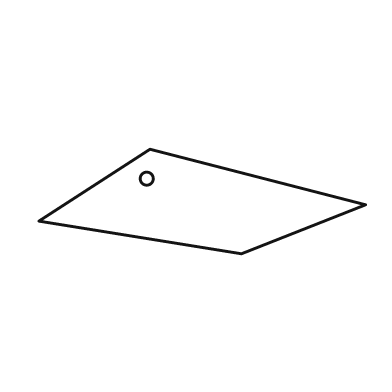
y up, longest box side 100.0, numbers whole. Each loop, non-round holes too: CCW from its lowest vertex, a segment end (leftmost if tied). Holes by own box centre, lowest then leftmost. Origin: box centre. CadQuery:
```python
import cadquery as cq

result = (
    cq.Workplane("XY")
    .moveTo(12.0, -16.0)
    .lineTo(50.0, -1.0)
    .lineTo(-16.0, 16.0)
    .lineTo(-50.0, -6.0)
    .close()
    .moveTo(-17.0, 7.0)
    .circle(2.0)
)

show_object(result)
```